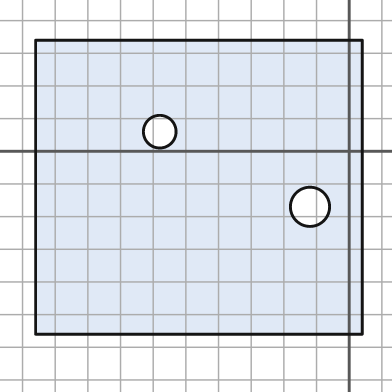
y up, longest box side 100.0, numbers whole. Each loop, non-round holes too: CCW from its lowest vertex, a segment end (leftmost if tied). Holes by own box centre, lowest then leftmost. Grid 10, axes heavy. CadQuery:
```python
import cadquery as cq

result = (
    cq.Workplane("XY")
    .moveTo(-96.0, -56.0)
    .lineTo(4.0, -56.0)
    .lineTo(4.0, 34.0)
    .lineTo(-96.0, 34.0)
    .close()
    .moveTo(-12.0, -17.0)
    .circle(6.0)
    .moveTo(-58.0, 6.0)
    .circle(5.0)
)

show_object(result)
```